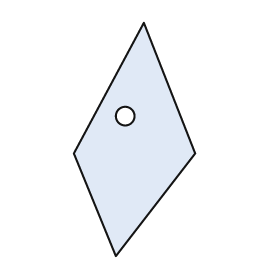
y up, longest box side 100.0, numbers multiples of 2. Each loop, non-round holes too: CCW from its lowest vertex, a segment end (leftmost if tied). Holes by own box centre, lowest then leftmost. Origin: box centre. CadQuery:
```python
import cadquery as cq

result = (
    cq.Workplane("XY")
    .moveTo(-8.0, -50.0)
    .lineTo(26.0, -6.0)
    .lineTo(4.0, 50.0)
    .lineTo(-26.0, -6.0)
    .close()
    .moveTo(-4.0, 10.0)
    .circle(4.0)
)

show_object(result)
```